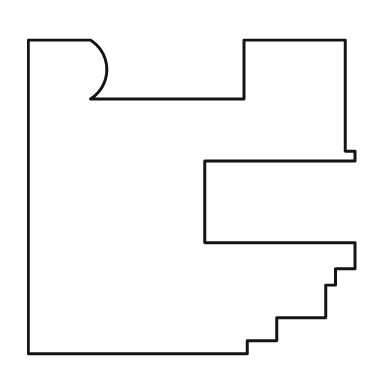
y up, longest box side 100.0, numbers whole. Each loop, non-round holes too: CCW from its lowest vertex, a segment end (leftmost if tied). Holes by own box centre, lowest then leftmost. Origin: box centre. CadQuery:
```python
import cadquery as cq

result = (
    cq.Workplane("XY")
    .moveTo(-50.0, -48.0)
    .lineTo(17.0, -48.0)
    .lineTo(17.0, -44.0)
    .lineTo(26.0, -44.0)
    .lineTo(26.0, -37.0)
    .lineTo(41.0, -37.0)
    .lineTo(41.0, -27.0)
    .lineTo(44.0, -27.0)
    .lineTo(44.0, -22.0)
    .lineTo(50.0, -22.0)
    .lineTo(50.0, -14.0)
    .lineTo(4.0, -14.0)
    .lineTo(4.0, 11.0)
    .lineTo(50.0, 11.0)
    .lineTo(50.0, 14.0)
    .lineTo(47.0, 14.0)
    .lineTo(47.0, 48.0)
    .lineTo(16.0, 48.0)
    .lineTo(16.0, 30.0)
    .lineTo(-31.0, 30.0)
    .threePointArc((-26.0, 39.0), (-31.0, 48.0))
    .lineTo(-50.0, 48.0)
    .close()
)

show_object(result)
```